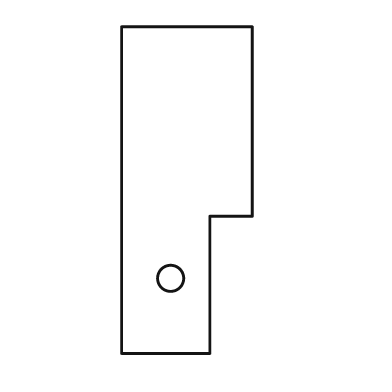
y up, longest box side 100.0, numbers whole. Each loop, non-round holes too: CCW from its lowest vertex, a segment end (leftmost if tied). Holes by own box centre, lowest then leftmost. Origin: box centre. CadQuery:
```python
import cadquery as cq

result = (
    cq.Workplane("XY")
    .moveTo(-20.0, -50.0)
    .lineTo(7.0, -50.0)
    .lineTo(7.0, -8.0)
    .lineTo(20.0, -8.0)
    .lineTo(20.0, 50.0)
    .lineTo(-20.0, 50.0)
    .close()
    .moveTo(-5.0, -27.0)
    .circle(4.0)
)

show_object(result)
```